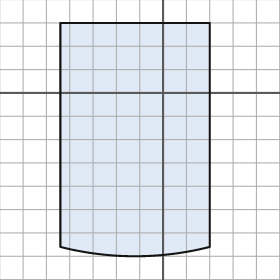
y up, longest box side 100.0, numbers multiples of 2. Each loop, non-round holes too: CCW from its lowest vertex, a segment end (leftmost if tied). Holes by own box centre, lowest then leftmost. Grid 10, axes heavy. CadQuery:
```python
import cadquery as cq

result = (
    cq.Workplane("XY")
    .moveTo(-44.0, -66.0)
    .threePointArc((-12.0, -70.0), (20.0, -66.0))
    .lineTo(20.0, 30.0)
    .lineTo(-44.0, 30.0)
    .close()
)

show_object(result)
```